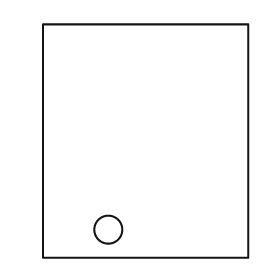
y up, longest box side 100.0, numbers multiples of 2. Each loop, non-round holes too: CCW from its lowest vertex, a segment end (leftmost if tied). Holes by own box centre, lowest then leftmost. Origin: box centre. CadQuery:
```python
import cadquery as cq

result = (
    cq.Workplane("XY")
    .moveTo(-44.0, -50.0)
    .lineTo(44.0, -50.0)
    .lineTo(44.0, 50.0)
    .lineTo(-44.0, 50.0)
    .close()
    .moveTo(-16.0, -38.0)
    .circle(6.0)
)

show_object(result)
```